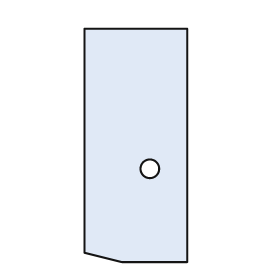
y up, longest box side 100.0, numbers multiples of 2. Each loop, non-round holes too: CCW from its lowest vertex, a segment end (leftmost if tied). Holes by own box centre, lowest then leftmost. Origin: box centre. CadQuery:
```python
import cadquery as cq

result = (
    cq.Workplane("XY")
    .moveTo(-6.0, -50.0)
    .lineTo(22.0, -50.0)
    .lineTo(22.0, 50.0)
    .lineTo(-22.0, 50.0)
    .lineTo(-22.0, -46.0)
    .close()
    .moveTo(6.0, -10.0)
    .circle(4.0)
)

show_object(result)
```